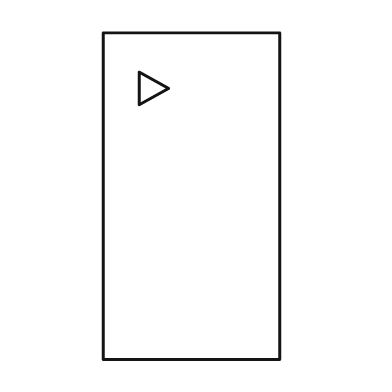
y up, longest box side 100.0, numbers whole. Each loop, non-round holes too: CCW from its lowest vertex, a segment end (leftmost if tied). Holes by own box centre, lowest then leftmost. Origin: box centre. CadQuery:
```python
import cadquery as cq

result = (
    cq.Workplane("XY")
    .moveTo(-27.0, -50.0)
    .lineTo(27.0, -50.0)
    .lineTo(27.0, 50.0)
    .lineTo(-27.0, 50.0)
    .close()
    .moveTo(-16.0, 28.0)
    .lineTo(-7.0, 33.0)
    .lineTo(-16.0, 38.0)
    .close()
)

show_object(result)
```